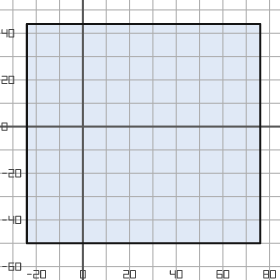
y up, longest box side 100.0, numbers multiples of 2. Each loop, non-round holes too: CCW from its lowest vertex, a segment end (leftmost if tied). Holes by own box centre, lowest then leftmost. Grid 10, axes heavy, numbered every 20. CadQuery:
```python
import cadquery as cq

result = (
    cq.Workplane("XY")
    .moveTo(-24.0, -50.0)
    .lineTo(76.0, -50.0)
    .lineTo(76.0, 44.0)
    .lineTo(-24.0, 44.0)
    .close()
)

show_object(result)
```